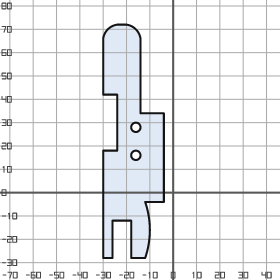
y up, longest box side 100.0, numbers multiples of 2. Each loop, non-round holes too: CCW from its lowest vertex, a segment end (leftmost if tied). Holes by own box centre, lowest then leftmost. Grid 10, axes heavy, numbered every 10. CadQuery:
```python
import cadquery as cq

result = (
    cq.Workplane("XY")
    .moveTo(-30.0, -28.0)
    .lineTo(-26.0, -28.0)
    .lineTo(-26.0, -12.0)
    .lineTo(-18.0, -12.0)
    .lineTo(-18.0, -28.0)
    .lineTo(-12.0, -28.0)
    .threePointArc((-10.0, -16.0), (-12.0, -4.0))
    .lineTo(-4.0, -4.0)
    .lineTo(-4.0, 34.0)
    .lineTo(-14.0, 34.0)
    .lineTo(-14.0, 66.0)
    .threePointArc((-16.0, 70.0), (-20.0, 72.0))
    .lineTo(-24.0, 72.0)
    .threePointArc((-28.0, 70.0), (-30.0, 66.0))
    .lineTo(-30.0, 42.0)
    .lineTo(-24.0, 42.0)
    .lineTo(-24.0, 18.0)
    .lineTo(-30.0, 18.0)
    .close()
    .moveTo(-16.0, 16.0)
    .circle(2.0)
    .moveTo(-16.0, 28.0)
    .circle(2.0)
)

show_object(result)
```